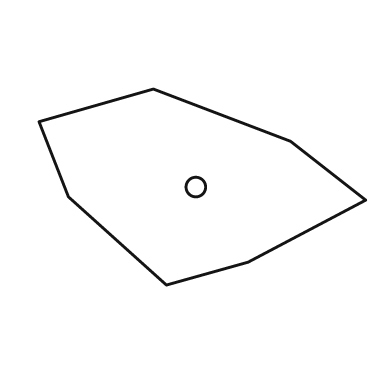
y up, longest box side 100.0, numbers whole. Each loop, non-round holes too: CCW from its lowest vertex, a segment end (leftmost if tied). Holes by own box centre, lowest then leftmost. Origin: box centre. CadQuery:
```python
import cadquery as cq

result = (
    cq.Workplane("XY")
    .moveTo(-11.0, -30.0)
    .lineTo(14.0, -23.0)
    .lineTo(50.0, -4.0)
    .lineTo(27.0, 14.0)
    .lineTo(-15.0, 30.0)
    .lineTo(-50.0, 20.0)
    .lineTo(-41.0, -3.0)
    .close()
    .moveTo(-2.0, 0.0)
    .circle(3.0)
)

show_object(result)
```